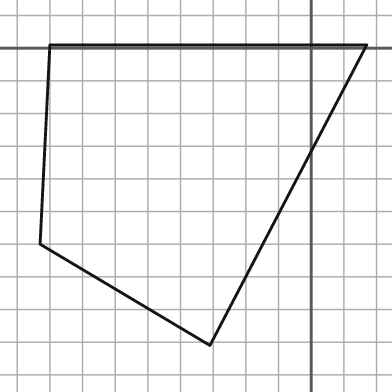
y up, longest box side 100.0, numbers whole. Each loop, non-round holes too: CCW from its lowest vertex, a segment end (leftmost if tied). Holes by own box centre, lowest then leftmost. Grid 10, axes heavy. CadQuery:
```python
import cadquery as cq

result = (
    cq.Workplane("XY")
    .moveTo(-31.0, -91.0)
    .lineTo(17.0, 1.0)
    .lineTo(-80.0, 1.0)
    .lineTo(-83.0, -60.0)
    .close()
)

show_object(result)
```